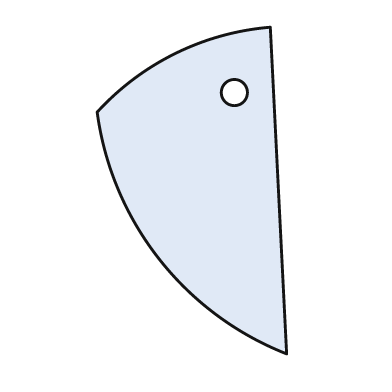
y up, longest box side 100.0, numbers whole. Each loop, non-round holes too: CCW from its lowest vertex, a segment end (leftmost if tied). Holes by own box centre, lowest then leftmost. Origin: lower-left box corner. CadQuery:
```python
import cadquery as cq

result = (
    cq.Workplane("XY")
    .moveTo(58.0, 0.0)
    .lineTo(53.0, 100.0)
    .threePointArc((24.0, 92.0), (0.0, 74.0))
    .threePointArc((19.0, 29.0), (58.0, 0.0))
    .close()
    .moveTo(42.0, 80.0)
    .circle(4.0)
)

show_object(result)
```